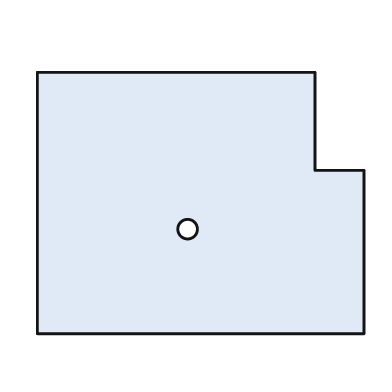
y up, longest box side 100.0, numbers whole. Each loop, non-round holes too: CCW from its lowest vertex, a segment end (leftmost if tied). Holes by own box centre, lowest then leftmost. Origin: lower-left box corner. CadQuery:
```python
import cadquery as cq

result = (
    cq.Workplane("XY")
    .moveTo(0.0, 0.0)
    .lineTo(100.0, 0.0)
    .lineTo(100.0, 50.0)
    .lineTo(85.0, 50.0)
    .lineTo(85.0, 80.0)
    .lineTo(0.0, 80.0)
    .close()
    .moveTo(46.0, 32.0)
    .circle(3.0)
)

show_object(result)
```